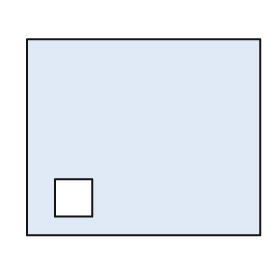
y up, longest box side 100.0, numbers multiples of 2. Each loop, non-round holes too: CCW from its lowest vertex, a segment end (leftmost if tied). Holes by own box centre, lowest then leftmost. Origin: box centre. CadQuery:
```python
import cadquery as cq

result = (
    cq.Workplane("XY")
    .moveTo(-50.0, -42.0)
    .lineTo(50.0, -42.0)
    .lineTo(50.0, 42.0)
    .lineTo(-50.0, 42.0)
    .close()
    .moveTo(-38.0, -34.0)
    .lineTo(-22.0, -34.0)
    .lineTo(-22.0, -18.0)
    .lineTo(-38.0, -18.0)
    .close()
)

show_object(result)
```